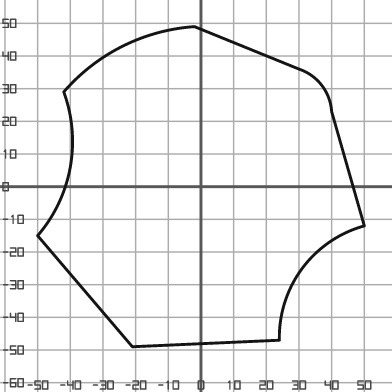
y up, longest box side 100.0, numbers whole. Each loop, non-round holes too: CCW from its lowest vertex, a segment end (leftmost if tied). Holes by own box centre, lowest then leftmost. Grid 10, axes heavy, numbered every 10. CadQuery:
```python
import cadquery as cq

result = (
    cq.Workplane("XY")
    .moveTo(-21.0, -49.0)
    .lineTo(24.0, -47.0)
    .threePointArc((31.0, -25.0), (50.0, -12.0))
    .lineTo(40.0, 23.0)
    .threePointArc((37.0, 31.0), (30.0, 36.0))
    .lineTo(-2.0, 49.0)
    .threePointArc((-24.0, 43.0), (-42.0, 29.0))
    .threePointArc((-40.0, 6.0), (-50.0, -15.0))
    .close()
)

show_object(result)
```